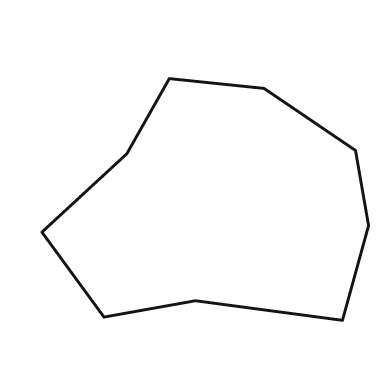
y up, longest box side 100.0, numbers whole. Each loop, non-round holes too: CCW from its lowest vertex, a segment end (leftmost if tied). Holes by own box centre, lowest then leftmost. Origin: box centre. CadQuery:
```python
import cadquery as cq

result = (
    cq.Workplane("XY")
    .moveTo(42.0, -37.0)
    .lineTo(50.0, -8.0)
    .lineTo(46.0, 15.0)
    .lineTo(18.0, 34.0)
    .lineTo(-11.0, 37.0)
    .lineTo(-24.0, 14.0)
    .lineTo(-50.0, -10.0)
    .lineTo(-31.0, -36.0)
    .lineTo(-3.0, -31.0)
    .close()
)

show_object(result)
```